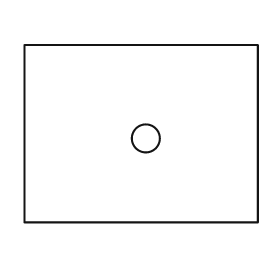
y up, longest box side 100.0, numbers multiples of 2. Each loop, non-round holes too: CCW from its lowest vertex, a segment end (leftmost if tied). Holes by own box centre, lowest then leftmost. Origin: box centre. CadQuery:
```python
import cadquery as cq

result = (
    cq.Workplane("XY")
    .moveTo(-50.0, -38.0)
    .lineTo(50.0, -38.0)
    .lineTo(50.0, 38.0)
    .lineTo(-50.0, 38.0)
    .close()
    .moveTo(2.0, -2.0)
    .circle(6.0)
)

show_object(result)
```